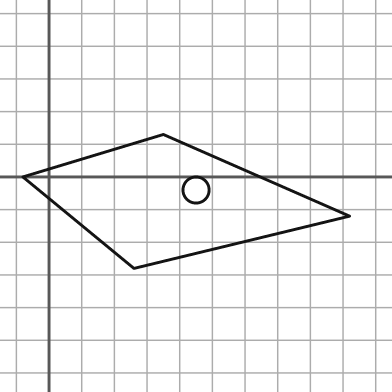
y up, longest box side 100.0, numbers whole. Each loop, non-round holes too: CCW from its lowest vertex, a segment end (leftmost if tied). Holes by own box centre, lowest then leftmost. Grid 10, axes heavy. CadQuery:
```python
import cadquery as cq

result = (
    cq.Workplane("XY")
    .moveTo(26.0, -28.0)
    .lineTo(92.0, -12.0)
    .lineTo(35.0, 13.0)
    .lineTo(-8.0, 0.0)
    .close()
    .moveTo(45.0, -4.0)
    .circle(4.0)
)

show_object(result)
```